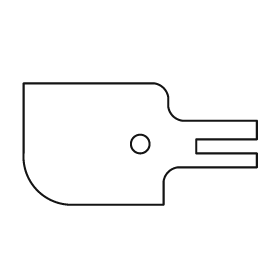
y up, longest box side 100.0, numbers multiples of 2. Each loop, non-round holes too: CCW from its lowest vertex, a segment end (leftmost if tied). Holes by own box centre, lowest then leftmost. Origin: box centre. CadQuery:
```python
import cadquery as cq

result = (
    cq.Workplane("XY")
    .moveTo(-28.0, -26.0)
    .lineTo(10.0, -26.0)
    .lineTo(10.0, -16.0)
    .threePointArc((12.0, -12.0), (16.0, -10.0))
    .lineTo(50.0, -10.0)
    .lineTo(50.0, -4.0)
    .lineTo(24.0, -4.0)
    .lineTo(24.0, 2.0)
    .lineTo(50.0, 2.0)
    .lineTo(50.0, 10.0)
    .lineTo(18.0, 10.0)
    .threePointArc((14.0, 12.0), (12.0, 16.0))
    .lineTo(12.0, 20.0)
    .threePointArc((10.0, 24.0), (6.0, 26.0))
    .lineTo(-50.0, 26.0)
    .lineTo(-50.0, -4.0)
    .threePointArc((-44.0, -20.0), (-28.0, -26.0))
    .close()
    .moveTo(0.0, 0.0)
    .circle(4.0)
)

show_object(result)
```